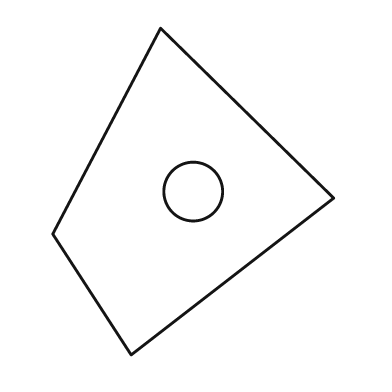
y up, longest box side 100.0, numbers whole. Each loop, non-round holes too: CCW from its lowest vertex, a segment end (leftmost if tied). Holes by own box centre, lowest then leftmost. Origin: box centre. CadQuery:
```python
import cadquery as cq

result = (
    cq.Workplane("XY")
    .moveTo(-19.0, -50.0)
    .lineTo(43.0, -2.0)
    .lineTo(-10.0, 50.0)
    .lineTo(-43.0, -13.0)
    .close()
    .moveTo(0.0, 0.0)
    .circle(9.0)
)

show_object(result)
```